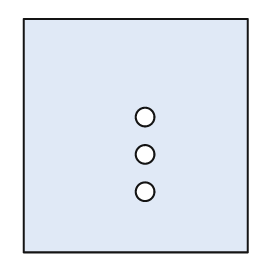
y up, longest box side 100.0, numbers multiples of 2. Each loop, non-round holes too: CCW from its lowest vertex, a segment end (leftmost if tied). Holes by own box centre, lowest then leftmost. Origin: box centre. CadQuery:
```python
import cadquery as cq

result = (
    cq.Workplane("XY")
    .moveTo(-48.0, -50.0)
    .lineTo(48.0, -50.0)
    .lineTo(48.0, 50.0)
    .lineTo(-48.0, 50.0)
    .close()
    .moveTo(4.0, -24.0)
    .circle(4.0)
    .moveTo(4.0, -8.0)
    .circle(4.0)
    .moveTo(4.0, 8.0)
    .circle(4.0)
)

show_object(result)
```